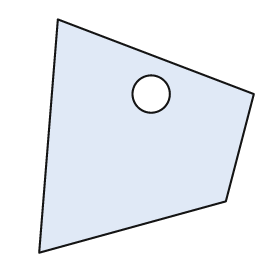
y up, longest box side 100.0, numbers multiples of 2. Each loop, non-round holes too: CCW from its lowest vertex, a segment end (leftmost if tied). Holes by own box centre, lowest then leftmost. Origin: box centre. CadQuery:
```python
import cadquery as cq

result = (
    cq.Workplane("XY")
    .moveTo(-46.0, -50.0)
    .lineTo(34.0, -28.0)
    .lineTo(46.0, 18.0)
    .lineTo(-38.0, 50.0)
    .close()
    .moveTo(2.0, 18.0)
    .circle(8.0)
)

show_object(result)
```